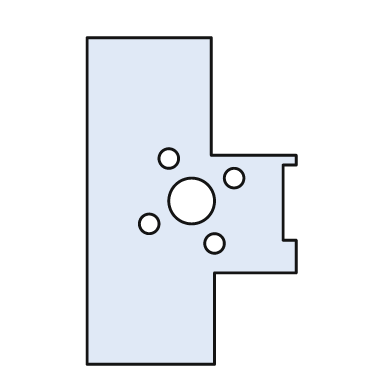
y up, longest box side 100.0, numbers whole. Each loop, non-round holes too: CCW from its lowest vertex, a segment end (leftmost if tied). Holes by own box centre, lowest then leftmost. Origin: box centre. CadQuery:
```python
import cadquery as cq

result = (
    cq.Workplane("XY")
    .moveTo(-32.0, -50.0)
    .lineTo(7.0, -50.0)
    .lineTo(7.0, -22.0)
    .lineTo(32.0, -22.0)
    .lineTo(32.0, -12.0)
    .lineTo(28.0, -12.0)
    .lineTo(28.0, 11.0)
    .lineTo(32.0, 11.0)
    .lineTo(32.0, 14.0)
    .lineTo(6.0, 14.0)
    .lineTo(6.0, 50.0)
    .lineTo(-32.0, 50.0)
    .close()
    .moveTo(7.0, -13.0)
    .circle(3.0)
    .moveTo(-13.0, -7.0)
    .circle(3.0)
    .moveTo(0.0, 0.0)
    .circle(7.0)
    .moveTo(13.0, 7.0)
    .circle(3.0)
    .moveTo(-7.0, 13.0)
    .circle(3.0)
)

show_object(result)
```